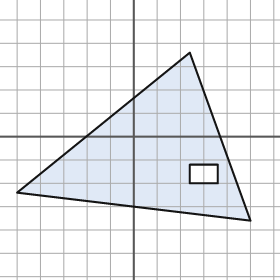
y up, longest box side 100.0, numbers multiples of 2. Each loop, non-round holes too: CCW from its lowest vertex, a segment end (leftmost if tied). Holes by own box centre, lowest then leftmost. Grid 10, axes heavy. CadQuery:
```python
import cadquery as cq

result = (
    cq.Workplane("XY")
    .moveTo(50.0, -36.0)
    .lineTo(24.0, 36.0)
    .lineTo(-50.0, -24.0)
    .close()
    .moveTo(24.0, -20.0)
    .lineTo(36.0, -20.0)
    .lineTo(36.0, -12.0)
    .lineTo(24.0, -12.0)
    .close()
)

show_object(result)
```